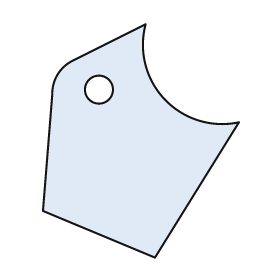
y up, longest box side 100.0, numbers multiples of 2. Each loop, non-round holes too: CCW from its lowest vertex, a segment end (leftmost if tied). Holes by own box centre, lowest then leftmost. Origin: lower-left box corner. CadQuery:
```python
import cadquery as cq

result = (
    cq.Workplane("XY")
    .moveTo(48.0, 0.0)
    .lineTo(84.0, 58.0)
    .threePointArc((52.0, 68.0), (44.0, 100.0))
    .lineTo(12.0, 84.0)
    .threePointArc((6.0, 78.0), (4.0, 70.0))
    .lineTo(0.0, 20.0)
    .close()
    .moveTo(24.0, 72.0)
    .circle(6.0)
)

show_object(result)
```